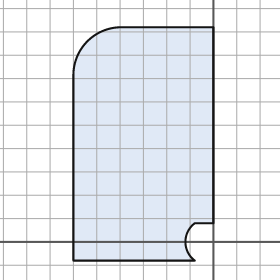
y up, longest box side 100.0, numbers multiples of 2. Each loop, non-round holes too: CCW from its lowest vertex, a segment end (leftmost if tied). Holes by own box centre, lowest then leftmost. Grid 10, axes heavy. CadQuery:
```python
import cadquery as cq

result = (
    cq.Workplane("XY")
    .moveTo(-60.0, -8.0)
    .lineTo(-8.0, -8.0)
    .threePointArc((-12.0, 0.0), (-8.0, 8.0))
    .lineTo(0.0, 8.0)
    .lineTo(0.0, 92.0)
    .lineTo(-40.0, 92.0)
    .threePointArc((-54.0, 86.0), (-60.0, 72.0))
    .close()
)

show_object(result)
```